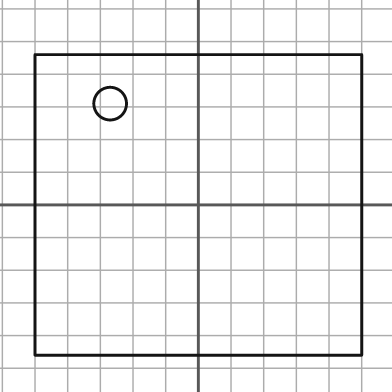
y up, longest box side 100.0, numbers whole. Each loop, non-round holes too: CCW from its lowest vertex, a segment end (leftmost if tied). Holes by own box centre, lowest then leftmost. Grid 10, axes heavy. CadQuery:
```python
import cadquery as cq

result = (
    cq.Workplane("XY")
    .moveTo(-50.0, -46.0)
    .lineTo(50.0, -46.0)
    .lineTo(50.0, 46.0)
    .lineTo(-50.0, 46.0)
    .close()
    .moveTo(-27.0, 31.0)
    .circle(5.0)
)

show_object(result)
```